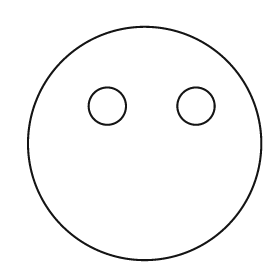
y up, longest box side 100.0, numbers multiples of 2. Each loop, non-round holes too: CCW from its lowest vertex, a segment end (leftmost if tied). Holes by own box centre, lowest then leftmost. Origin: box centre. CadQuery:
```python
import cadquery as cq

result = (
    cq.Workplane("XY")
    .moveTo(0.0, 0.0)
    .circle(50.0)
    .moveTo(-16.0, 16.0)
    .circle(8.0)
    .moveTo(22.0, 16.0)
    .circle(8.0)
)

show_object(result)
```